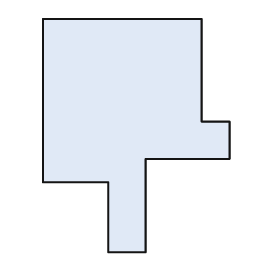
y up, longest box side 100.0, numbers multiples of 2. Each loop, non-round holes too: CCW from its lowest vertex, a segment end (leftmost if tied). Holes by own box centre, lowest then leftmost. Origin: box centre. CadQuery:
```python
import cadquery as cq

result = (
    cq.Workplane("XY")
    .moveTo(-12.0, -50.0)
    .lineTo(4.0, -50.0)
    .lineTo(4.0, -10.0)
    .lineTo(40.0, -10.0)
    .lineTo(40.0, 6.0)
    .lineTo(28.0, 6.0)
    .lineTo(28.0, 50.0)
    .lineTo(-40.0, 50.0)
    .lineTo(-40.0, -20.0)
    .lineTo(-12.0, -20.0)
    .close()
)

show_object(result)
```